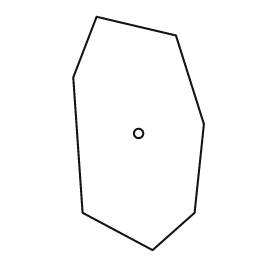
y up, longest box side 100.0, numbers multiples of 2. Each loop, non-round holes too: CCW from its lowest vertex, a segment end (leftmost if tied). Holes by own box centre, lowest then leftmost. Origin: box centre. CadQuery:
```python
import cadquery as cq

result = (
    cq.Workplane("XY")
    .moveTo(6.0, -50.0)
    .lineTo(24.0, -34.0)
    .lineTo(28.0, 4.0)
    .lineTo(16.0, 42.0)
    .lineTo(-18.0, 50.0)
    .lineTo(-28.0, 24.0)
    .lineTo(-24.0, -34.0)
    .close()
    .moveTo(0.0, 0.0)
    .circle(2.0)
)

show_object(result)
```